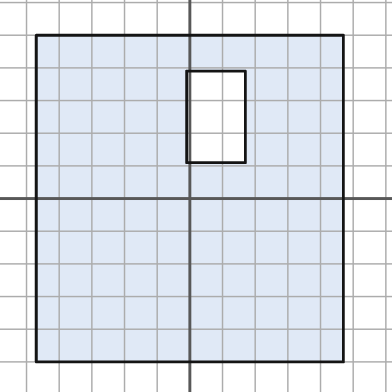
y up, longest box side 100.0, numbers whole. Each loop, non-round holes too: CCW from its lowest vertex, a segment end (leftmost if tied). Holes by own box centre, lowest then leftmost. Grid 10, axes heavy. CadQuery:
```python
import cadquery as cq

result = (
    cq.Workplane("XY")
    .moveTo(-47.0, -50.0)
    .lineTo(47.0, -50.0)
    .lineTo(47.0, 50.0)
    .lineTo(-47.0, 50.0)
    .close()
    .moveTo(-1.0, 11.0)
    .lineTo(17.0, 11.0)
    .lineTo(17.0, 39.0)
    .lineTo(-1.0, 39.0)
    .close()
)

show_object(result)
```